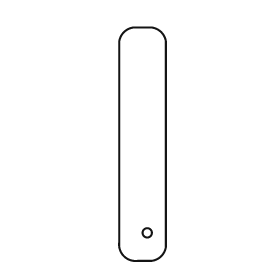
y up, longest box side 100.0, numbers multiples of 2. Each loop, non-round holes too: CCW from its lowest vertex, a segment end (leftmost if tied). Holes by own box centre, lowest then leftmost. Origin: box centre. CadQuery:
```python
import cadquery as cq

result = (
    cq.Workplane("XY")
    .moveTo(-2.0, -50.0)
    .lineTo(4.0, -50.0)
    .threePointArc((8.0, -48.0), (10.0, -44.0))
    .lineTo(10.0, 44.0)
    .threePointArc((8.0, 48.0), (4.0, 50.0))
    .lineTo(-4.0, 50.0)
    .threePointArc((-8.0, 48.0), (-10.0, 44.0))
    .lineTo(-10.0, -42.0)
    .threePointArc((-8.0, -48.0), (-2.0, -50.0))
    .close()
    .moveTo(2.0, -38.0)
    .circle(2.0)
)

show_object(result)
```